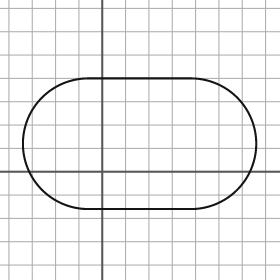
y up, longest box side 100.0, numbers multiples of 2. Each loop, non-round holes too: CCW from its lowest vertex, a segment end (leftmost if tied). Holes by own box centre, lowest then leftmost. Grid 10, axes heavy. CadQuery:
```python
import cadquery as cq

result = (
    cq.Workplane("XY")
    .moveTo(-6.0, -16.0)
    .lineTo(38.0, -16.0)
    .threePointArc((66.0, 12.0), (38.0, 40.0))
    .lineTo(-6.0, 40.0)
    .threePointArc((-34.0, 12.0), (-6.0, -16.0))
    .close()
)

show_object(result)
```